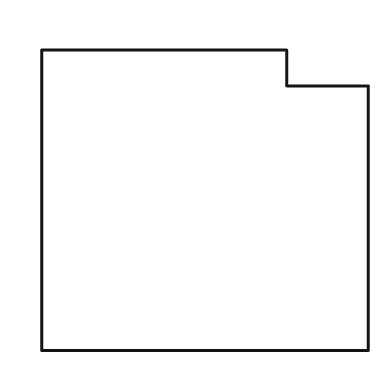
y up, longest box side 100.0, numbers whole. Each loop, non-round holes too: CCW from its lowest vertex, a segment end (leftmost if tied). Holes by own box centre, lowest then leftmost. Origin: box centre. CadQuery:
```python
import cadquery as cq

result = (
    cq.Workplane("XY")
    .moveTo(-50.0, -46.0)
    .lineTo(50.0, -46.0)
    .lineTo(50.0, 35.0)
    .lineTo(25.0, 35.0)
    .lineTo(25.0, 46.0)
    .lineTo(-50.0, 46.0)
    .close()
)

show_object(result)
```